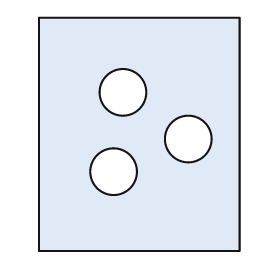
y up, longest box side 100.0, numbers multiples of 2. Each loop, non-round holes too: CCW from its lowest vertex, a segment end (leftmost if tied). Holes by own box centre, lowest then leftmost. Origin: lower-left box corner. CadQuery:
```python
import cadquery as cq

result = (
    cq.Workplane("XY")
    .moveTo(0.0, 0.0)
    .lineTo(86.0, 0.0)
    .lineTo(86.0, 100.0)
    .lineTo(0.0, 100.0)
    .close()
    .moveTo(32.0, 34.0)
    .circle(10.0)
    .moveTo(64.0, 48.0)
    .circle(10.0)
    .moveTo(36.0, 68.0)
    .circle(10.0)
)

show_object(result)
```